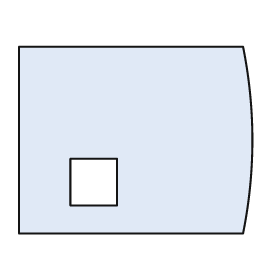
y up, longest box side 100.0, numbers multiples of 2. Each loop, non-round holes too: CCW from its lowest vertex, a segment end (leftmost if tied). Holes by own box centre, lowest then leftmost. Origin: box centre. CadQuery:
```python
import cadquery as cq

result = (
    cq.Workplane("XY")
    .moveTo(-50.0, -40.0)
    .lineTo(46.0, -40.0)
    .threePointArc((50.0, 0.0), (46.0, 40.0))
    .lineTo(-50.0, 40.0)
    .close()
    .moveTo(-28.0, -28.0)
    .lineTo(-8.0, -28.0)
    .lineTo(-8.0, -8.0)
    .lineTo(-28.0, -8.0)
    .close()
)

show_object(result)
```